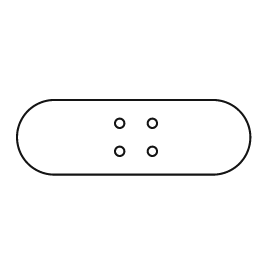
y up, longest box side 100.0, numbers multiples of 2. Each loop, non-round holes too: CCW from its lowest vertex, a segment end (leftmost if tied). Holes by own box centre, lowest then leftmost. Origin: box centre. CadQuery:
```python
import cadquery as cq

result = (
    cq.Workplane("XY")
    .moveTo(-34.0, -16.0)
    .lineTo(34.0, -16.0)
    .threePointArc((50.0, 0.0), (34.0, 16.0))
    .lineTo(-34.0, 16.0)
    .threePointArc((-50.0, 0.0), (-34.0, -16.0))
    .close()
    .moveTo(-6.0, -6.0)
    .circle(2.0)
    .moveTo(8.0, -6.0)
    .circle(2.0)
    .moveTo(-6.0, 6.0)
    .circle(2.0)
    .moveTo(8.0, 6.0)
    .circle(2.0)
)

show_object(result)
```